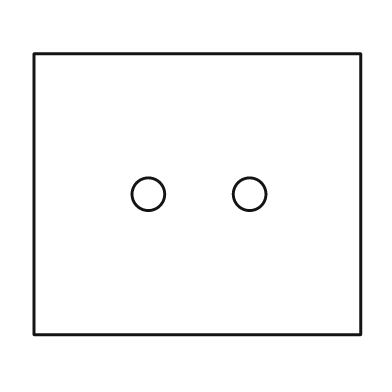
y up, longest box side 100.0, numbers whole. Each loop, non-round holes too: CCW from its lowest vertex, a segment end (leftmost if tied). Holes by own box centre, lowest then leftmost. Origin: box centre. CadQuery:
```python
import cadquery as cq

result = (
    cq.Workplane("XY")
    .moveTo(-50.0, -43.0)
    .lineTo(50.0, -43.0)
    .lineTo(50.0, 43.0)
    .lineTo(-50.0, 43.0)
    .close()
    .moveTo(-15.0, 0.0)
    .circle(5.0)
    .moveTo(16.0, 0.0)
    .circle(5.0)
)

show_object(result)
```